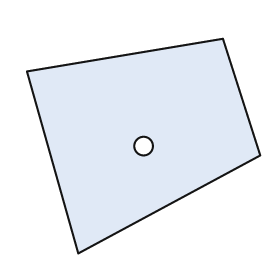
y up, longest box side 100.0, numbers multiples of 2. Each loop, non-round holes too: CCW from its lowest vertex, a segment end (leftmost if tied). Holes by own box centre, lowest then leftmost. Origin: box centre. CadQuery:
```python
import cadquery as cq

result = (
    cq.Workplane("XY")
    .moveTo(-28.0, -46.0)
    .lineTo(50.0, -4.0)
    .lineTo(34.0, 46.0)
    .lineTo(-50.0, 32.0)
    .close()
    .moveTo(0.0, 0.0)
    .circle(4.0)
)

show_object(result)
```